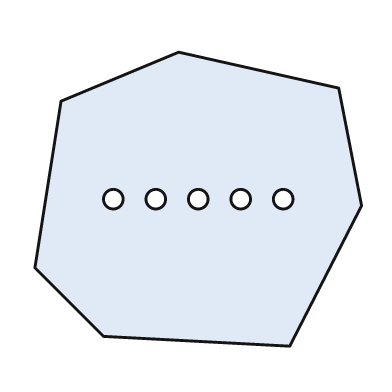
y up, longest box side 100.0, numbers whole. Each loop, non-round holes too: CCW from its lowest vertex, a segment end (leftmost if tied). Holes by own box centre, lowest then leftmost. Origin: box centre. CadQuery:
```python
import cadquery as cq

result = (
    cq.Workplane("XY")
    .moveTo(28.0, -45.0)
    .lineTo(50.0, -2.0)
    .lineTo(43.0, 34.0)
    .lineTo(-6.0, 45.0)
    .lineTo(-42.0, 30.0)
    .lineTo(-50.0, -21.0)
    .lineTo(-29.0, -42.0)
    .close()
    .moveTo(-26.0, 0.0)
    .circle(3.0)
    .moveTo(-13.0, 0.0)
    .circle(3.0)
    .moveTo(0.0, 0.0)
    .circle(3.0)
    .moveTo(13.0, 0.0)
    .circle(3.0)
    .moveTo(26.0, 0.0)
    .circle(3.0)
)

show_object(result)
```